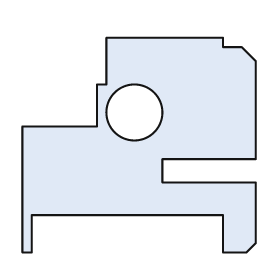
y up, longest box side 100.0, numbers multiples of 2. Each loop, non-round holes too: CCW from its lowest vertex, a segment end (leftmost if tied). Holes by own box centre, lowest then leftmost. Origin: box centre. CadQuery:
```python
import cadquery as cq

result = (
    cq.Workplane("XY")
    .moveTo(-50.0, -46.0)
    .lineTo(-46.0, -46.0)
    .lineTo(-46.0, -30.0)
    .lineTo(36.0, -30.0)
    .lineTo(36.0, -46.0)
    .lineTo(46.0, -46.0)
    .lineTo(50.0, -42.0)
    .lineTo(50.0, -16.0)
    .lineTo(10.0, -16.0)
    .lineTo(10.0, -6.0)
    .lineTo(50.0, -6.0)
    .lineTo(50.0, 36.0)
    .lineTo(44.0, 42.0)
    .lineTo(36.0, 42.0)
    .lineTo(36.0, 46.0)
    .lineTo(-14.0, 46.0)
    .lineTo(-14.0, 26.0)
    .lineTo(-18.0, 26.0)
    .lineTo(-18.0, 8.0)
    .lineTo(-50.0, 8.0)
    .close()
    .moveTo(-2.0, 14.0)
    .circle(12.0)
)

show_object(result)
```